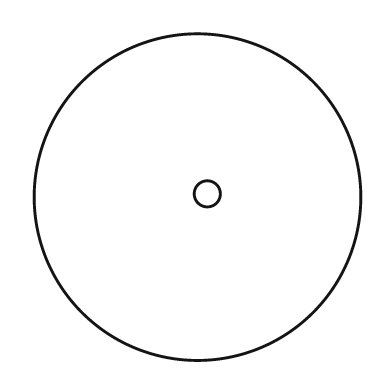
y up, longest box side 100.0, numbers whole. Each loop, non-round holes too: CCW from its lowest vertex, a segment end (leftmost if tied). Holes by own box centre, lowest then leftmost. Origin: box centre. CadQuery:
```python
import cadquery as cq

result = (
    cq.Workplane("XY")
    .moveTo(0.0, 0.0)
    .circle(50.0)
    .moveTo(3.0, 1.0)
    .circle(4.0)
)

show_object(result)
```